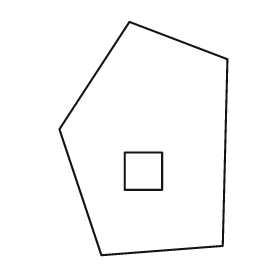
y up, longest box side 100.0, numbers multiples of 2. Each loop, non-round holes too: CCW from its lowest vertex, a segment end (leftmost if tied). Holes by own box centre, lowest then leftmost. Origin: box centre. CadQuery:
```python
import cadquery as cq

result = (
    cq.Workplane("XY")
    .moveTo(-18.0, -50.0)
    .lineTo(34.0, -46.0)
    .lineTo(36.0, 34.0)
    .lineTo(-6.0, 50.0)
    .lineTo(-36.0, 4.0)
    .close()
    .moveTo(-8.0, -22.0)
    .lineTo(8.0, -22.0)
    .lineTo(8.0, -6.0)
    .lineTo(-8.0, -6.0)
    .close()
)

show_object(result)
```